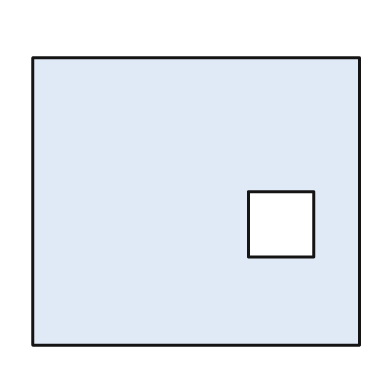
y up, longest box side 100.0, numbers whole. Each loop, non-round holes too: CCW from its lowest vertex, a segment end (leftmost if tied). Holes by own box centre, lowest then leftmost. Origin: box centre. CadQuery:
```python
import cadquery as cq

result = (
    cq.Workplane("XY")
    .moveTo(-50.0, -44.0)
    .lineTo(50.0, -44.0)
    .lineTo(50.0, 44.0)
    .lineTo(-50.0, 44.0)
    .close()
    .moveTo(16.0, -17.0)
    .lineTo(36.0, -17.0)
    .lineTo(36.0, 3.0)
    .lineTo(16.0, 3.0)
    .close()
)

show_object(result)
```